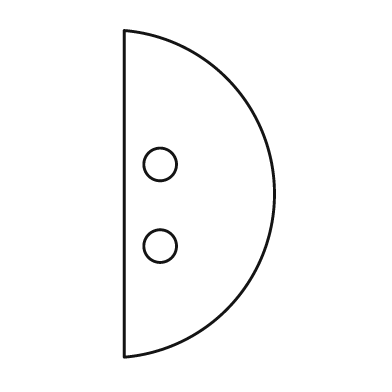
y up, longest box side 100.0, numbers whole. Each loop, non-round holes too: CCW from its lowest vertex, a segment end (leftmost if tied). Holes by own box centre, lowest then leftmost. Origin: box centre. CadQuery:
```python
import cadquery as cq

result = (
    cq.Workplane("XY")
    .moveTo(-23.0, -50.0)
    .threePointArc((23.0, 0.0), (-23.0, 50.0))
    .close()
    .moveTo(-12.0, -16.0)
    .circle(5.0)
    .moveTo(-12.0, 9.0)
    .circle(5.0)
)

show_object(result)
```